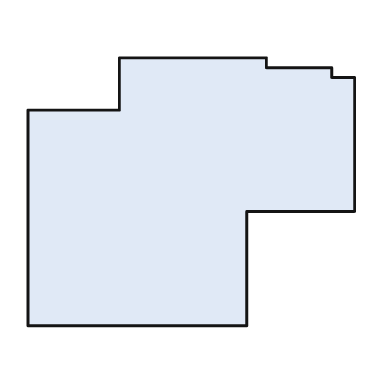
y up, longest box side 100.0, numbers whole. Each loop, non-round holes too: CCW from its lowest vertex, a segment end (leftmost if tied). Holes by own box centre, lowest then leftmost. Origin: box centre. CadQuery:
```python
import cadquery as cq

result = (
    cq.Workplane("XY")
    .moveTo(-50.0, -41.0)
    .lineTo(17.0, -41.0)
    .lineTo(17.0, -6.0)
    .lineTo(50.0, -6.0)
    .lineTo(50.0, 35.0)
    .lineTo(43.0, 35.0)
    .lineTo(43.0, 38.0)
    .lineTo(23.0, 38.0)
    .lineTo(23.0, 41.0)
    .lineTo(-22.0, 41.0)
    .lineTo(-22.0, 25.0)
    .lineTo(-50.0, 25.0)
    .close()
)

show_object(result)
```